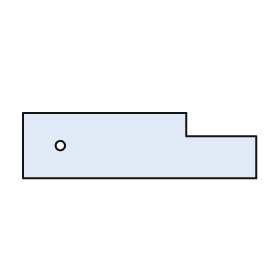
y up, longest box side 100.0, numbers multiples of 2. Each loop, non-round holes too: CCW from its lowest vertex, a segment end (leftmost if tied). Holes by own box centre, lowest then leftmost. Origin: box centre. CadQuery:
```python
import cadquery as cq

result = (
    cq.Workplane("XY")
    .moveTo(-50.0, -14.0)
    .lineTo(50.0, -14.0)
    .lineTo(50.0, 4.0)
    .lineTo(20.0, 4.0)
    .lineTo(20.0, 14.0)
    .lineTo(-50.0, 14.0)
    .close()
    .moveTo(-34.0, 0.0)
    .circle(2.0)
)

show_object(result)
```